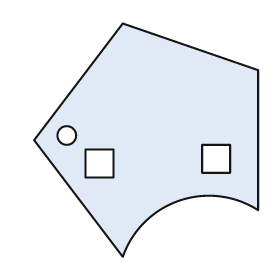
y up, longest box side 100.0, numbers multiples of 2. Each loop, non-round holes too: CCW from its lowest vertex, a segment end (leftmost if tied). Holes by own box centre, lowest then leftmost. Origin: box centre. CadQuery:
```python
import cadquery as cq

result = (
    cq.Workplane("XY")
    .moveTo(-10.0, -50.0)
    .threePointArc((14.0, -26.0), (48.0, -30.0))
    .lineTo(48.0, 30.0)
    .lineTo(-10.0, 50.0)
    .lineTo(-48.0, 0.0)
    .close()
    .moveTo(-26.0, -16.0)
    .lineTo(-14.0, -16.0)
    .lineTo(-14.0, -4.0)
    .lineTo(-26.0, -4.0)
    .close()
    .moveTo(24.0, -14.0)
    .lineTo(36.0, -14.0)
    .lineTo(36.0, -2.0)
    .lineTo(24.0, -2.0)
    .close()
    .moveTo(-34.0, 2.0)
    .circle(4.0)
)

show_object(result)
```